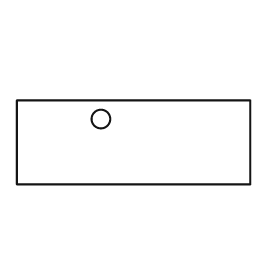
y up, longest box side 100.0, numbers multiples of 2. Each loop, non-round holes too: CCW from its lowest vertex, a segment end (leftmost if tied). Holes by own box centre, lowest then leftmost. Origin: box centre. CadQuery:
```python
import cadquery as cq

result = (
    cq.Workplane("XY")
    .moveTo(-50.0, -18.0)
    .lineTo(50.0, -18.0)
    .lineTo(50.0, 18.0)
    .lineTo(-50.0, 18.0)
    .close()
    .moveTo(-14.0, 10.0)
    .circle(4.0)
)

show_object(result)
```